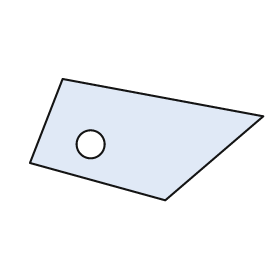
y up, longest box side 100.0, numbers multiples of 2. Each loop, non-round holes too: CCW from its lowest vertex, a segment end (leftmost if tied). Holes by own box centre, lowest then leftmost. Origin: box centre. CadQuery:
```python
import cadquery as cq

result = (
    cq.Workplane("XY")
    .moveTo(8.0, -26.0)
    .lineTo(50.0, 10.0)
    .lineTo(-36.0, 26.0)
    .lineTo(-50.0, -10.0)
    .close()
    .moveTo(-24.0, -2.0)
    .circle(6.0)
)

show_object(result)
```